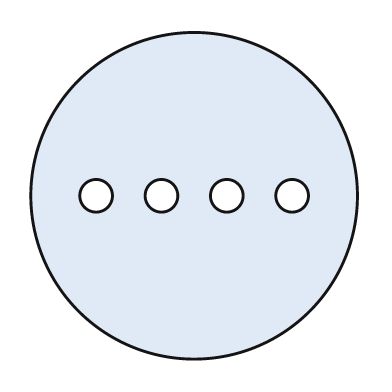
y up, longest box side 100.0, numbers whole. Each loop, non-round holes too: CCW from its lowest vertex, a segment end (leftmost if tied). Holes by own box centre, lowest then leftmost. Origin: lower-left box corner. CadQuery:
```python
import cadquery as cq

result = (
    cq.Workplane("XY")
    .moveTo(50.0, 50.0)
    .circle(50.0)
    .moveTo(20.0, 50.0)
    .circle(5.0)
    .moveTo(40.0, 50.0)
    .circle(5.0)
    .moveTo(60.0, 50.0)
    .circle(5.0)
    .moveTo(80.0, 50.0)
    .circle(5.0)
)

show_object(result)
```